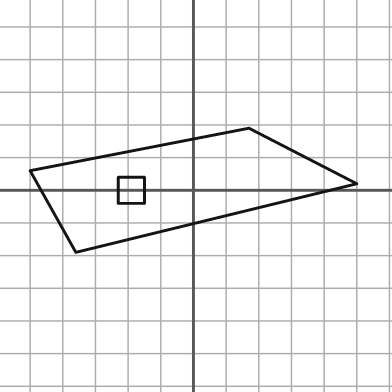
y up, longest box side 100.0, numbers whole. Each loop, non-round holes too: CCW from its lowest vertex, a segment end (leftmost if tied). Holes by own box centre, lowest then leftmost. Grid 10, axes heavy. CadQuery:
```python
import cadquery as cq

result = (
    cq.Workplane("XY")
    .moveTo(-36.0, -19.0)
    .lineTo(50.0, 2.0)
    .lineTo(17.0, 19.0)
    .lineTo(-50.0, 6.0)
    .close()
    .moveTo(-23.0, -4.0)
    .lineTo(-15.0, -4.0)
    .lineTo(-15.0, 4.0)
    .lineTo(-23.0, 4.0)
    .close()
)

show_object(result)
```